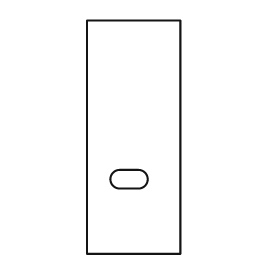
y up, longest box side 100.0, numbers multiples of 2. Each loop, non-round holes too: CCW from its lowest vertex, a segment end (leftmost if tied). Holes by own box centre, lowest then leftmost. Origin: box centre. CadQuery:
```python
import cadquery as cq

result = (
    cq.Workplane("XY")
    .moveTo(-20.0, -50.0)
    .lineTo(20.0, -50.0)
    .lineTo(20.0, 50.0)
    .lineTo(-20.0, 50.0)
    .close()
    .moveTo(-6.0, -22.0)
    .lineTo(2.0, -22.0)
    .threePointArc((6.0, -18.0), (2.0, -14.0))
    .lineTo(-6.0, -14.0)
    .threePointArc((-10.0, -18.0), (-6.0, -22.0))
    .close()
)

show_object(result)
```